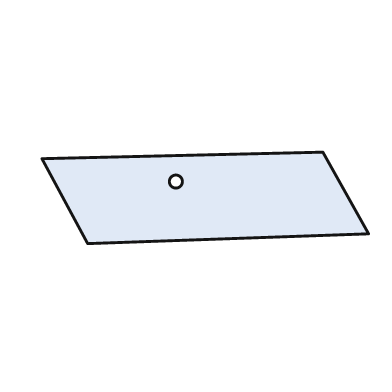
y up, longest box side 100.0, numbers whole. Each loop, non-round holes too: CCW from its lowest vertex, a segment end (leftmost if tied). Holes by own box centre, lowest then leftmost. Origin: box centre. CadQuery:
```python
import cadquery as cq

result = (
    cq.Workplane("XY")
    .moveTo(-36.0, -14.0)
    .lineTo(50.0, -11.0)
    .lineTo(36.0, 14.0)
    .lineTo(-50.0, 12.0)
    .close()
    .moveTo(-9.0, 5.0)
    .circle(2.0)
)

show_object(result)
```